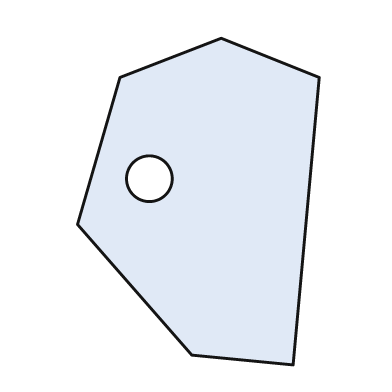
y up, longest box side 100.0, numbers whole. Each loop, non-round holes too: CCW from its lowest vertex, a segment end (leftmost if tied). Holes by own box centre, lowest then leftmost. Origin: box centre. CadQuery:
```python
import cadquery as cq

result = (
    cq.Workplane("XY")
    .moveTo(29.0, -50.0)
    .lineTo(37.0, 38.0)
    .lineTo(7.0, 50.0)
    .lineTo(-24.0, 38.0)
    .lineTo(-37.0, -7.0)
    .lineTo(-2.0, -47.0)
    .close()
    .moveTo(-15.0, 7.0)
    .circle(7.0)
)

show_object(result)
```